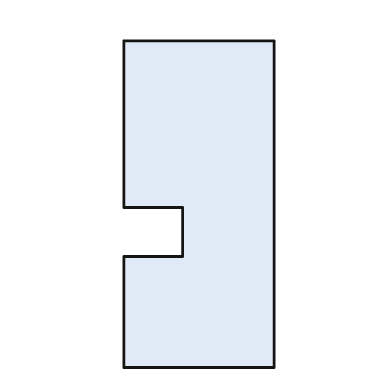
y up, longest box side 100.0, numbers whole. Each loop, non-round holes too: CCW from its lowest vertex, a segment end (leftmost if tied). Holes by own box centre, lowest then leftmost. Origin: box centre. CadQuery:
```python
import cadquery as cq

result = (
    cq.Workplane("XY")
    .moveTo(-23.0, -50.0)
    .lineTo(23.0, -50.0)
    .lineTo(23.0, 50.0)
    .lineTo(-23.0, 50.0)
    .lineTo(-23.0, -1.0)
    .lineTo(-5.0, -1.0)
    .lineTo(-5.0, -16.0)
    .lineTo(-23.0, -16.0)
    .close()
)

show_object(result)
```